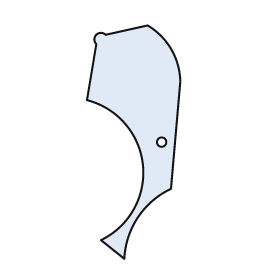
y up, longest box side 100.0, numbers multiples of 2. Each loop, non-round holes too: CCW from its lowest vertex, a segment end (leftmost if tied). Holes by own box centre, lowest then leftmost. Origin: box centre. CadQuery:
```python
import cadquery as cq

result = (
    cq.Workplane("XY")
    .moveTo(-4.0, -50.0)
    .threePointArc((2.0, -32.0), (16.0, -20.0))
    .lineTo(20.0, 26.0)
    .threePointArc((16.0, 40.0), (6.0, 50.0))
    .lineTo(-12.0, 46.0)
    .threePointArc((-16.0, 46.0), (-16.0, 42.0))
    .lineTo(-20.0, 18.0)
    .threePointArc((4.0, -10.0), (-14.0, -42.0))
    .close()
    .moveTo(12.0, 0.0)
    .circle(2.0)
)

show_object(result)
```